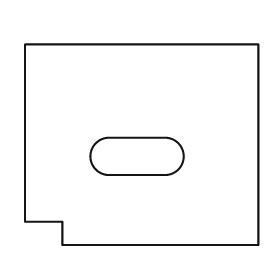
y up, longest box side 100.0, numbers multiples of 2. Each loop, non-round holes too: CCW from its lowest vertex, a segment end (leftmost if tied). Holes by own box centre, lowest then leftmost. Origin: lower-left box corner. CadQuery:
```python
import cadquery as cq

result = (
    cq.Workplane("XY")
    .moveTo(16.0, 0.0)
    .lineTo(100.0, 0.0)
    .lineTo(100.0, 86.0)
    .lineTo(0.0, 86.0)
    .lineTo(0.0, 10.0)
    .lineTo(16.0, 10.0)
    .close()
    .moveTo(36.0, 30.0)
    .lineTo(60.0, 30.0)
    .threePointArc((68.0, 38.0), (60.0, 46.0))
    .lineTo(36.0, 46.0)
    .threePointArc((28.0, 38.0), (36.0, 30.0))
    .close()
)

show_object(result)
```